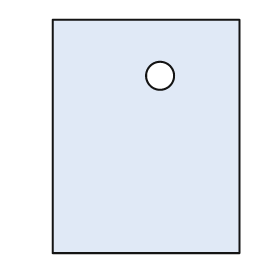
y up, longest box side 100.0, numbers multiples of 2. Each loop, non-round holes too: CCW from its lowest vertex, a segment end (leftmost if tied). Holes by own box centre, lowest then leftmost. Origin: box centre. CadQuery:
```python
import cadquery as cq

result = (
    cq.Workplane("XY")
    .moveTo(-40.0, -50.0)
    .lineTo(40.0, -50.0)
    .lineTo(40.0, 50.0)
    .lineTo(-40.0, 50.0)
    .close()
    .moveTo(6.0, 26.0)
    .circle(6.0)
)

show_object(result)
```